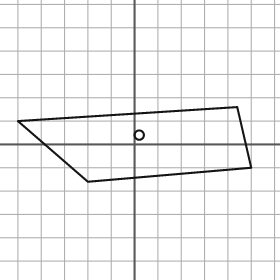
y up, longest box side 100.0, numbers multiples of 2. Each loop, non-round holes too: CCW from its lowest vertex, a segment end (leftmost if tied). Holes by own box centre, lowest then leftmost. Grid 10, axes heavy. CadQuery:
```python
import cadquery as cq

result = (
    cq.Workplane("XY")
    .moveTo(-20.0, -16.0)
    .lineTo(50.0, -10.0)
    .lineTo(44.0, 16.0)
    .lineTo(-50.0, 10.0)
    .close()
    .moveTo(2.0, 4.0)
    .circle(2.0)
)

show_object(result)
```